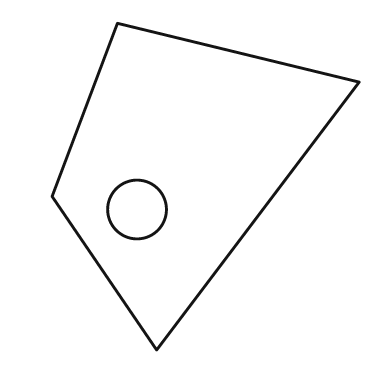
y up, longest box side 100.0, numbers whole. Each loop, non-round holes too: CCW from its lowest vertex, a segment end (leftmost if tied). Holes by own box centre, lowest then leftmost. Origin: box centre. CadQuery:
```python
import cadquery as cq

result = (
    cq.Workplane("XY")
    .moveTo(-15.0, -50.0)
    .lineTo(47.0, 32.0)
    .lineTo(-27.0, 50.0)
    .lineTo(-47.0, -3.0)
    .close()
    .moveTo(-21.0, -7.0)
    .circle(9.0)
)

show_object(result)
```